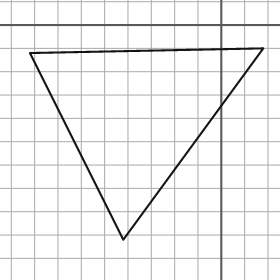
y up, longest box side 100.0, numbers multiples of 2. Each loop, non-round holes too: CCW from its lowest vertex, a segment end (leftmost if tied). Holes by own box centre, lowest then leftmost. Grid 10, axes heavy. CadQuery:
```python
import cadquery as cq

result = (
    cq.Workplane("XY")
    .moveTo(-42.0, -92.0)
    .lineTo(18.0, -10.0)
    .lineTo(-82.0, -12.0)
    .close()
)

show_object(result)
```